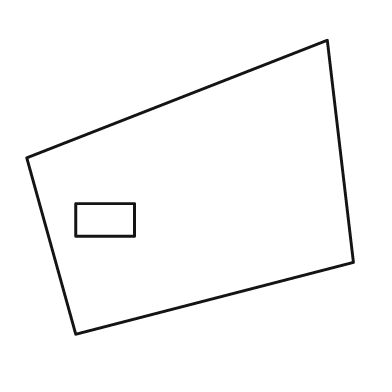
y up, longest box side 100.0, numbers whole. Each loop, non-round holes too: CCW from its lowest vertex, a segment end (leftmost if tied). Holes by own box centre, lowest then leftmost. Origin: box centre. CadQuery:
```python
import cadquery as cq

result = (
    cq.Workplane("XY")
    .moveTo(-35.0, -45.0)
    .lineTo(50.0, -23.0)
    .lineTo(42.0, 45.0)
    .lineTo(-50.0, 9.0)
    .close()
    .moveTo(-35.0, -15.0)
    .lineTo(-17.0, -15.0)
    .lineTo(-17.0, -5.0)
    .lineTo(-35.0, -5.0)
    .close()
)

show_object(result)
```